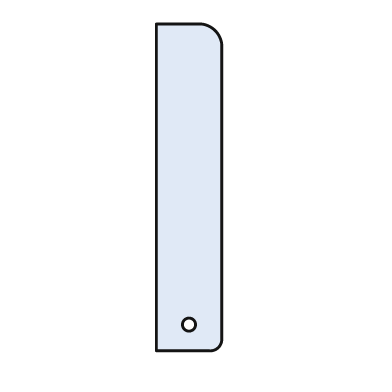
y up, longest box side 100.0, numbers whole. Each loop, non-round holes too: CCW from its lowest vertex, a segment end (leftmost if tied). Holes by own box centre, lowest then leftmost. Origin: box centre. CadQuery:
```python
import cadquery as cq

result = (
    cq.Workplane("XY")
    .moveTo(-10.0, -50.0)
    .lineTo(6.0, -50.0)
    .threePointArc((9.0, -49.0), (10.0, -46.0))
    .lineTo(10.0, 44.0)
    .threePointArc((8.0, 48.0), (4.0, 50.0))
    .lineTo(-10.0, 50.0)
    .close()
    .moveTo(0.0, -42.0)
    .circle(2.0)
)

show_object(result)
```